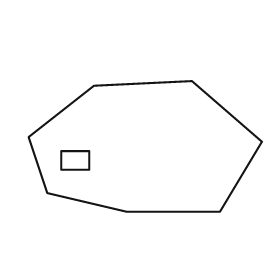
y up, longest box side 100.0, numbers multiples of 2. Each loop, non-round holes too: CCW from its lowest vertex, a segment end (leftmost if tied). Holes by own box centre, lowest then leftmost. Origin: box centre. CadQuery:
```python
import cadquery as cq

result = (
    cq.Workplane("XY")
    .moveTo(-8.0, -28.0)
    .lineTo(32.0, -28.0)
    .lineTo(50.0, 2.0)
    .lineTo(20.0, 28.0)
    .lineTo(-22.0, 26.0)
    .lineTo(-50.0, 4.0)
    .lineTo(-42.0, -20.0)
    .close()
    .moveTo(-36.0, -10.0)
    .lineTo(-24.0, -10.0)
    .lineTo(-24.0, -2.0)
    .lineTo(-36.0, -2.0)
    .close()
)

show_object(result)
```